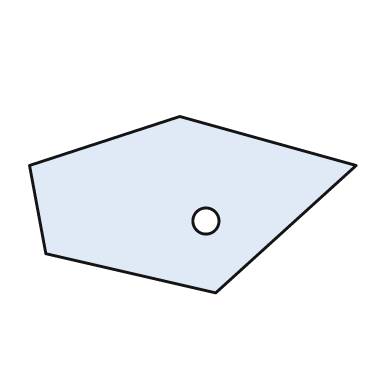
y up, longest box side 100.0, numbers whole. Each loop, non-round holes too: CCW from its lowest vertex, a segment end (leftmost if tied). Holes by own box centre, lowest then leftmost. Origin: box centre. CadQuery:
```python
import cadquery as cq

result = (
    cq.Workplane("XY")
    .moveTo(7.0, -27.0)
    .lineTo(50.0, 12.0)
    .lineTo(-4.0, 27.0)
    .lineTo(-50.0, 12.0)
    .lineTo(-45.0, -15.0)
    .close()
    .moveTo(4.0, -5.0)
    .circle(4.0)
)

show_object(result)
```